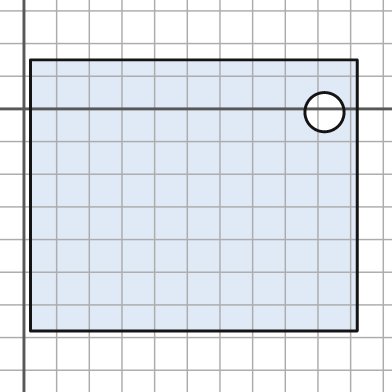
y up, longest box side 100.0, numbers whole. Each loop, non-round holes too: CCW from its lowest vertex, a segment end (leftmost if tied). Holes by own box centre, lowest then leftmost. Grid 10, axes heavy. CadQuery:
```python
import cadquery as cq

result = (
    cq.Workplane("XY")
    .moveTo(2.0, -68.0)
    .lineTo(102.0, -68.0)
    .lineTo(102.0, 15.0)
    .lineTo(2.0, 15.0)
    .close()
    .moveTo(92.0, -1.0)
    .circle(6.0)
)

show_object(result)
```